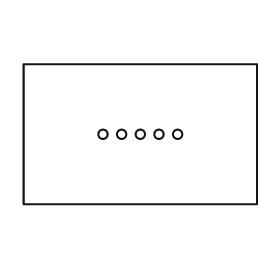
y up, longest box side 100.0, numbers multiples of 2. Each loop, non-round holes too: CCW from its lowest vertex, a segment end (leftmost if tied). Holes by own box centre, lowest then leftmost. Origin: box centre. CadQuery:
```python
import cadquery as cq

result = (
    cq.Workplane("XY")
    .moveTo(-50.0, -30.0)
    .lineTo(50.0, -30.0)
    .lineTo(50.0, 30.0)
    .lineTo(-50.0, 30.0)
    .close()
    .moveTo(-16.0, 0.0)
    .circle(2.0)
    .moveTo(-8.0, 0.0)
    .circle(2.0)
    .moveTo(0.0, 0.0)
    .circle(2.0)
    .moveTo(8.0, 0.0)
    .circle(2.0)
    .moveTo(16.0, 0.0)
    .circle(2.0)
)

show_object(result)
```